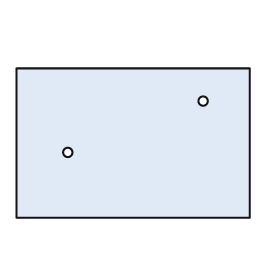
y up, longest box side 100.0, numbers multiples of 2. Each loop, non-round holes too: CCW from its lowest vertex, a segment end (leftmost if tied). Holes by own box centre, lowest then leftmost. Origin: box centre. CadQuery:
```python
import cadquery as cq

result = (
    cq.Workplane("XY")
    .moveTo(-50.0, -32.0)
    .lineTo(50.0, -32.0)
    .lineTo(50.0, 32.0)
    .lineTo(-50.0, 32.0)
    .close()
    .moveTo(-28.0, -4.0)
    .circle(2.0)
    .moveTo(30.0, 18.0)
    .circle(2.0)
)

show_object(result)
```